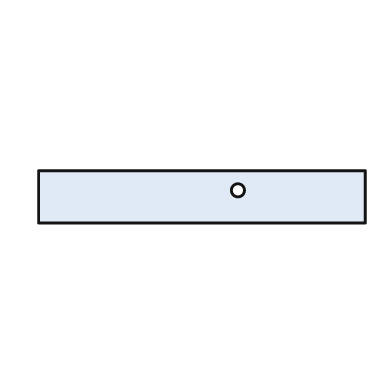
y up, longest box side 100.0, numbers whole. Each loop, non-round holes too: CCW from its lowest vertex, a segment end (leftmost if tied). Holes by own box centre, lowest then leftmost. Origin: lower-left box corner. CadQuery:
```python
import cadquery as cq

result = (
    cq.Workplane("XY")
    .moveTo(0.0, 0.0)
    .lineTo(100.0, 0.0)
    .lineTo(100.0, 16.0)
    .lineTo(0.0, 16.0)
    .close()
    .moveTo(61.0, 10.0)
    .circle(2.0)
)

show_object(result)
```